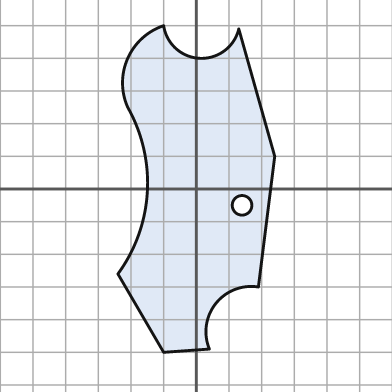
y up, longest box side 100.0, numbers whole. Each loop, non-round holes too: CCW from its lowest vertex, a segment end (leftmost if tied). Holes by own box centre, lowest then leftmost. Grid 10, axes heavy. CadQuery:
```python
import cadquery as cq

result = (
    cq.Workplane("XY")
    .moveTo(-10.0, -50.0)
    .lineTo(4.0, -49.0)
    .threePointArc((6.0, -35.0), (19.0, -30.0))
    .lineTo(24.0, 10.0)
    .lineTo(13.0, 49.0)
    .threePointArc((1.0, 40.0), (-10.0, 50.0))
    .threePointArc((-21.0, 40.0), (-21.0, 25.0))
    .threePointArc((-15.0, -1.0), (-24.0, -26.0))
    .close()
    .moveTo(14.0, -5.0)
    .circle(3.0)
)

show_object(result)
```